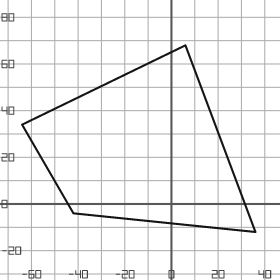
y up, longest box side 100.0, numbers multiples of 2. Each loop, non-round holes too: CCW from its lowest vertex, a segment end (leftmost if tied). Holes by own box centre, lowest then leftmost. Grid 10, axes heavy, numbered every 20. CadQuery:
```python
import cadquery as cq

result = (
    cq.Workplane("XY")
    .moveTo(36.0, -12.0)
    .lineTo(6.0, 68.0)
    .lineTo(-64.0, 34.0)
    .lineTo(-42.0, -4.0)
    .close()
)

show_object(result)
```